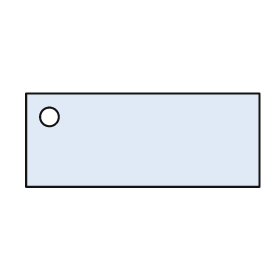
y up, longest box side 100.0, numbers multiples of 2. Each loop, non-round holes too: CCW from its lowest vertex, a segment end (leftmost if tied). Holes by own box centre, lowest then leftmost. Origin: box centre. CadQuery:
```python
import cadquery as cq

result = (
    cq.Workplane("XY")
    .moveTo(-50.0, -20.0)
    .lineTo(50.0, -20.0)
    .lineTo(50.0, 20.0)
    .lineTo(-50.0, 20.0)
    .close()
    .moveTo(-40.0, 10.0)
    .circle(4.0)
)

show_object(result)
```